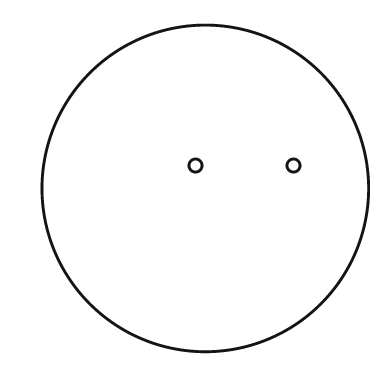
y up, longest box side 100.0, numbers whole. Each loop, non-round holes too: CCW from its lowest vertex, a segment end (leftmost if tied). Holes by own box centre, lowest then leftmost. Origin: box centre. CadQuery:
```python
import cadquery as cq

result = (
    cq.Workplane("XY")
    .moveTo(0.0, 0.0)
    .circle(50.0)
    .moveTo(-3.0, 7.0)
    .circle(2.0)
    .moveTo(27.0, 7.0)
    .circle(2.0)
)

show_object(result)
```